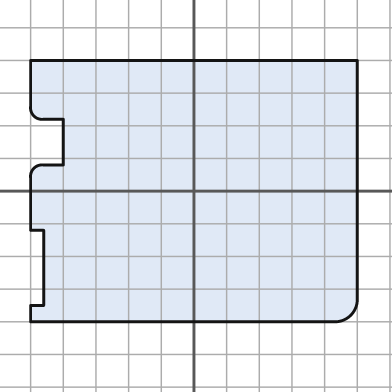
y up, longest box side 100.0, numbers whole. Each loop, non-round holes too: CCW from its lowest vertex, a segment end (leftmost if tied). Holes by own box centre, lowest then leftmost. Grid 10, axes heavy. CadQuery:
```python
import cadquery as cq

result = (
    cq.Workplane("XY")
    .moveTo(-50.0, -40.0)
    .lineTo(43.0, -40.0)
    .threePointArc((48.0, -38.0), (50.0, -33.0))
    .lineTo(50.0, 40.0)
    .lineTo(-50.0, 40.0)
    .lineTo(-50.0, 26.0)
    .threePointArc((-49.0, 23.0), (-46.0, 22.0))
    .lineTo(-40.0, 22.0)
    .lineTo(-40.0, 8.0)
    .lineTo(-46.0, 8.0)
    .threePointArc((-49.0, 7.0), (-50.0, 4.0))
    .lineTo(-50.0, -12.0)
    .lineTo(-46.0, -12.0)
    .lineTo(-46.0, -35.0)
    .lineTo(-50.0, -35.0)
    .close()
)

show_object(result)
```